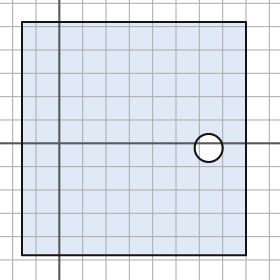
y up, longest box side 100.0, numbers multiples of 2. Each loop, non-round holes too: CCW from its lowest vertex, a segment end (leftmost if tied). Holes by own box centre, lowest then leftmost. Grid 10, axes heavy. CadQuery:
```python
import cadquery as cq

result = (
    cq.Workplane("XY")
    .moveTo(-16.0, -48.0)
    .lineTo(80.0, -48.0)
    .lineTo(80.0, 52.0)
    .lineTo(-16.0, 52.0)
    .close()
    .moveTo(64.0, -2.0)
    .circle(6.0)
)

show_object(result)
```